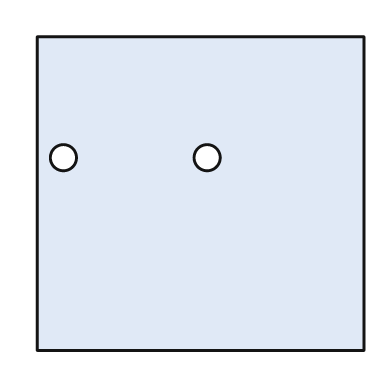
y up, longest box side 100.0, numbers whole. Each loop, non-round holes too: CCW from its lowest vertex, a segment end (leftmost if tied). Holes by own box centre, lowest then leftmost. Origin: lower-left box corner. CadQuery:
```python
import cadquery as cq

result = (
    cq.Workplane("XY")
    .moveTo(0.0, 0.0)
    .lineTo(100.0, 0.0)
    .lineTo(100.0, 96.0)
    .lineTo(0.0, 96.0)
    .close()
    .moveTo(8.0, 59.0)
    .circle(4.0)
    .moveTo(52.0, 59.0)
    .circle(4.0)
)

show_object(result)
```